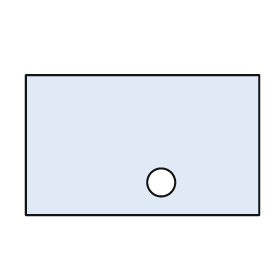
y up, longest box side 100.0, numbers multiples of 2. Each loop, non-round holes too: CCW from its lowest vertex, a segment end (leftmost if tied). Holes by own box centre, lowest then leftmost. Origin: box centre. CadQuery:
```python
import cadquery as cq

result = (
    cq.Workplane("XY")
    .moveTo(-50.0, -30.0)
    .lineTo(50.0, -30.0)
    .lineTo(50.0, 30.0)
    .lineTo(-50.0, 30.0)
    .close()
    .moveTo(8.0, -16.0)
    .circle(6.0)
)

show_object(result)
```